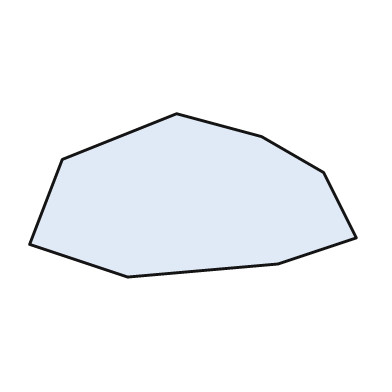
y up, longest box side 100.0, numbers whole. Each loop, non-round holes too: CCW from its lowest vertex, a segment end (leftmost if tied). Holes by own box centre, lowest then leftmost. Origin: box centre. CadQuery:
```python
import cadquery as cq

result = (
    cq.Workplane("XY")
    .moveTo(-20.0, -25.0)
    .lineTo(26.0, -21.0)
    .lineTo(50.0, -13.0)
    .lineTo(40.0, 7.0)
    .lineTo(21.0, 18.0)
    .lineTo(-5.0, 25.0)
    .lineTo(-40.0, 11.0)
    .lineTo(-50.0, -15.0)
    .close()
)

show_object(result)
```